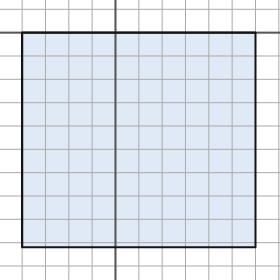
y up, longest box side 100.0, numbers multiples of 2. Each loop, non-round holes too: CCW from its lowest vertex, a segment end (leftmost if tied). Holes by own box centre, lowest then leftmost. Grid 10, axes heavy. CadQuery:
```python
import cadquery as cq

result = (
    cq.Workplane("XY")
    .moveTo(-40.0, -92.0)
    .lineTo(60.0, -92.0)
    .lineTo(60.0, 0.0)
    .lineTo(-40.0, 0.0)
    .close()
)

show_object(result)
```